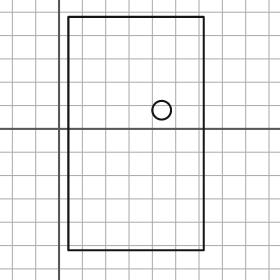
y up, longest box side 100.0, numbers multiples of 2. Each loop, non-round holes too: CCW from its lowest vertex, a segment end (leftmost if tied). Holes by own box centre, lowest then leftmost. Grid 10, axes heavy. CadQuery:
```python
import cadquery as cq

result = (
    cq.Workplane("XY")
    .moveTo(4.0, -52.0)
    .lineTo(62.0, -52.0)
    .lineTo(62.0, 48.0)
    .lineTo(4.0, 48.0)
    .close()
    .moveTo(44.0, 8.0)
    .circle(4.0)
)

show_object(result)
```